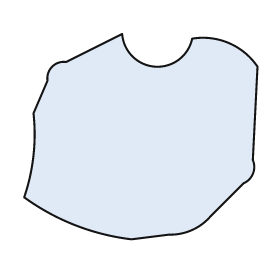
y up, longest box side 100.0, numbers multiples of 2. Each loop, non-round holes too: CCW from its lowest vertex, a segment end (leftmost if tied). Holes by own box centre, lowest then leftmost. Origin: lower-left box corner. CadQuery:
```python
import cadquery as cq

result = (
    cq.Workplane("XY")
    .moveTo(46.0, 0.0)
    .lineTo(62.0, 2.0)
    .threePointArc((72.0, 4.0), (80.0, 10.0))
    .lineTo(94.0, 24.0)
    .threePointArc((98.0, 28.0), (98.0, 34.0))
    .lineTo(100.0, 74.0)
    .threePointArc((88.0, 84.0), (72.0, 86.0))
    .threePointArc((56.0, 74.0), (42.0, 88.0))
    .lineTo(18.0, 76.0)
    .threePointArc((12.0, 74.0), (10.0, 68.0))
    .lineTo(4.0, 54.0)
    .threePointArc((4.0, 36.0), (0.0, 18.0))
    .threePointArc((22.0, 6.0), (46.0, 0.0))
    .close()
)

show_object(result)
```